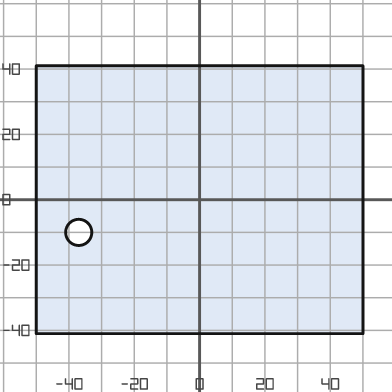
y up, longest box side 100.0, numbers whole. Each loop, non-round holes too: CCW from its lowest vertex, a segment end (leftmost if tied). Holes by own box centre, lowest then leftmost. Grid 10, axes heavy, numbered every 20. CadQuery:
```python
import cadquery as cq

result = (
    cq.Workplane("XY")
    .moveTo(-50.0, -41.0)
    .lineTo(50.0, -41.0)
    .lineTo(50.0, 41.0)
    .lineTo(-50.0, 41.0)
    .close()
    .moveTo(-37.0, -10.0)
    .circle(4.0)
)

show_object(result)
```